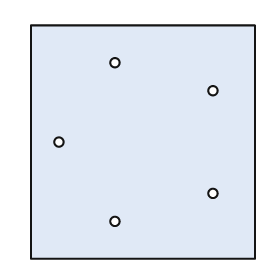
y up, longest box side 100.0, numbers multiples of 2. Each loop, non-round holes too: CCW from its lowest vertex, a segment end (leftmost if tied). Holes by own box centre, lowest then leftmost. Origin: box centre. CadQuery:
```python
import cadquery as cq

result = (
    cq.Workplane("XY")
    .moveTo(-48.0, -50.0)
    .lineTo(48.0, -50.0)
    .lineTo(48.0, 50.0)
    .lineTo(-48.0, 50.0)
    .close()
    .moveTo(-12.0, -34.0)
    .circle(2.0)
    .moveTo(30.0, -22.0)
    .circle(2.0)
    .moveTo(-36.0, 0.0)
    .circle(2.0)
    .moveTo(30.0, 22.0)
    .circle(2.0)
    .moveTo(-12.0, 34.0)
    .circle(2.0)
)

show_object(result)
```